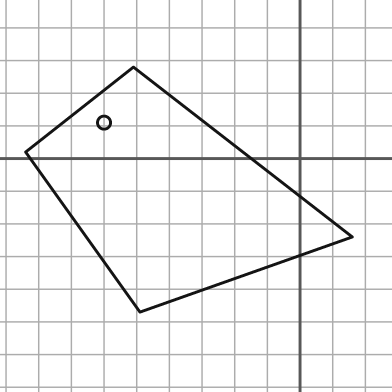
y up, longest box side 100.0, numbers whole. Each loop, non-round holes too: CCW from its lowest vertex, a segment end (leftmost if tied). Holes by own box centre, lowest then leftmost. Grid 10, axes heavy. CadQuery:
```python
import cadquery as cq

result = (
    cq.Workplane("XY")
    .moveTo(-49.0, -47.0)
    .lineTo(16.0, -24.0)
    .lineTo(-51.0, 28.0)
    .lineTo(-84.0, 2.0)
    .close()
    .moveTo(-60.0, 11.0)
    .circle(2.0)
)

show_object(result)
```